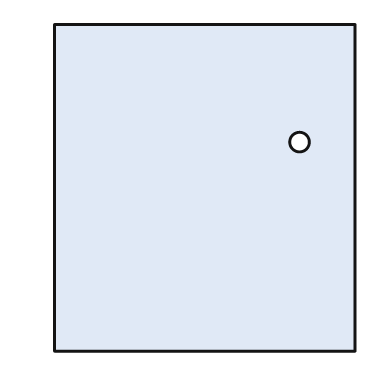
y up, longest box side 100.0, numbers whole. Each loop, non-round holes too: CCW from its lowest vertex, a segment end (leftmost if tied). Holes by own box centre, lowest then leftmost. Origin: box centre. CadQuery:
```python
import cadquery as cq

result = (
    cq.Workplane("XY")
    .moveTo(-46.0, -50.0)
    .lineTo(46.0, -50.0)
    .lineTo(46.0, 50.0)
    .lineTo(-46.0, 50.0)
    .close()
    .moveTo(29.0, 14.0)
    .circle(3.0)
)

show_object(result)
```